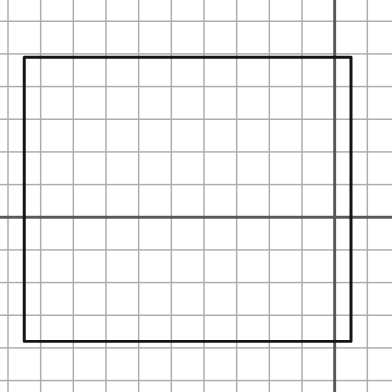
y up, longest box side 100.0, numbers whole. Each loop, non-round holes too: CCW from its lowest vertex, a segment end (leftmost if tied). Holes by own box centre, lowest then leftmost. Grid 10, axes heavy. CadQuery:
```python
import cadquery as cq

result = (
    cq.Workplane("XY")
    .moveTo(-95.0, -38.0)
    .lineTo(5.0, -38.0)
    .lineTo(5.0, 49.0)
    .lineTo(-95.0, 49.0)
    .close()
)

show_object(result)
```